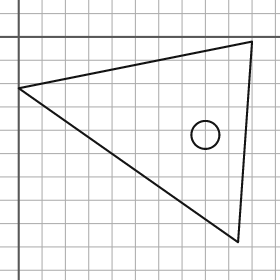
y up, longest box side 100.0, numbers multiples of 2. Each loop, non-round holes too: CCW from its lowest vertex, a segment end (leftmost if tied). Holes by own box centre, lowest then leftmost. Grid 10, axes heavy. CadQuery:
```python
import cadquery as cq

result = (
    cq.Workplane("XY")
    .moveTo(94.0, -88.0)
    .lineTo(100.0, -2.0)
    .lineTo(0.0, -22.0)
    .close()
    .moveTo(80.0, -42.0)
    .circle(6.0)
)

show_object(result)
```